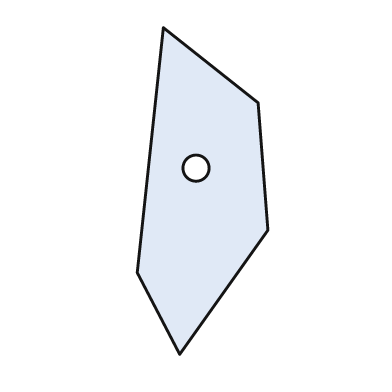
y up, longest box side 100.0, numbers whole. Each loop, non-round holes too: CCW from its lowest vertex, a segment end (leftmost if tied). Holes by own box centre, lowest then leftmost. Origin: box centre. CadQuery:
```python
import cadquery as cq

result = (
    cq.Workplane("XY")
    .moveTo(-7.0, -50.0)
    .lineTo(20.0, -12.0)
    .lineTo(17.0, 27.0)
    .lineTo(-12.0, 50.0)
    .lineTo(-20.0, -25.0)
    .close()
    .moveTo(-2.0, 7.0)
    .circle(4.0)
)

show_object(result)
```